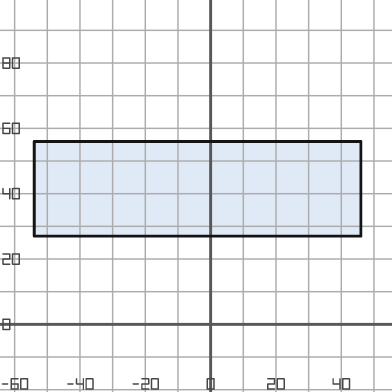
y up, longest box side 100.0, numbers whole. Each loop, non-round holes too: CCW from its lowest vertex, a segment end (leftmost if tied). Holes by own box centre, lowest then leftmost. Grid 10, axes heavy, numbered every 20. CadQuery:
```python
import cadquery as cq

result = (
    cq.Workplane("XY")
    .moveTo(-54.0, 27.0)
    .lineTo(46.0, 27.0)
    .lineTo(46.0, 56.0)
    .lineTo(-54.0, 56.0)
    .close()
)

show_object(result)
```